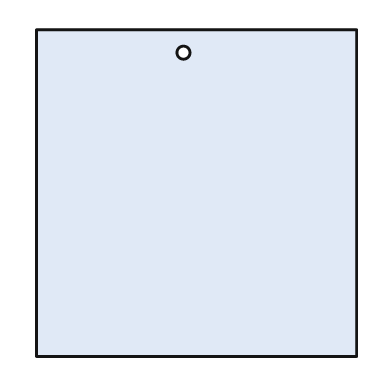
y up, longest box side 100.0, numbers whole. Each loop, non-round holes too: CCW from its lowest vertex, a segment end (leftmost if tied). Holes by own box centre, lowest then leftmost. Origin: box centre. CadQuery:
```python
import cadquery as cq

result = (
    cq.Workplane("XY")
    .moveTo(-49.0, -50.0)
    .lineTo(49.0, -50.0)
    .lineTo(49.0, 50.0)
    .lineTo(-49.0, 50.0)
    .close()
    .moveTo(-4.0, 43.0)
    .circle(2.0)
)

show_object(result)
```